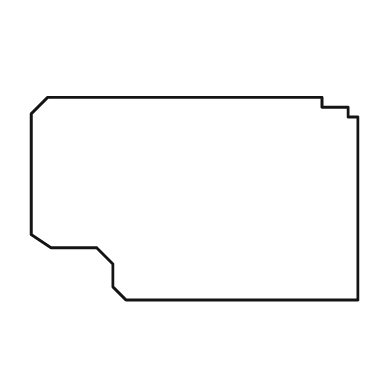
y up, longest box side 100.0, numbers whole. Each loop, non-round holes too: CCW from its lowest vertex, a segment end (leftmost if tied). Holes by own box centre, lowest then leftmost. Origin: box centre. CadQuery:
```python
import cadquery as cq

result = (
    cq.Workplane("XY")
    .moveTo(-21.0, -31.0)
    .lineTo(50.0, -31.0)
    .lineTo(50.0, 25.0)
    .lineTo(47.0, 25.0)
    .lineTo(47.0, 28.0)
    .lineTo(39.0, 28.0)
    .lineTo(39.0, 31.0)
    .lineTo(-45.0, 31.0)
    .lineTo(-50.0, 26.0)
    .lineTo(-50.0, -11.0)
    .lineTo(-44.0, -15.0)
    .lineTo(-30.0, -15.0)
    .lineTo(-25.0, -20.0)
    .lineTo(-25.0, -27.0)
    .close()
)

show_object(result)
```